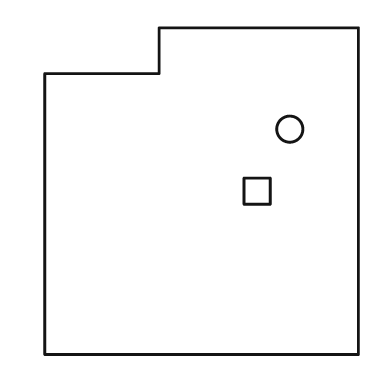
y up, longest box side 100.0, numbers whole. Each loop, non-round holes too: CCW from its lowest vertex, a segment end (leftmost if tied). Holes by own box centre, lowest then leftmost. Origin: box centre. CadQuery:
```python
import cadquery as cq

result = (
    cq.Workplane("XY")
    .moveTo(-48.0, -50.0)
    .lineTo(48.0, -50.0)
    .lineTo(48.0, 50.0)
    .lineTo(-13.0, 50.0)
    .lineTo(-13.0, 36.0)
    .lineTo(-48.0, 36.0)
    .close()
    .moveTo(13.0, -4.0)
    .lineTo(21.0, -4.0)
    .lineTo(21.0, 4.0)
    .lineTo(13.0, 4.0)
    .close()
    .moveTo(27.0, 19.0)
    .circle(4.0)
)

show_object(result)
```